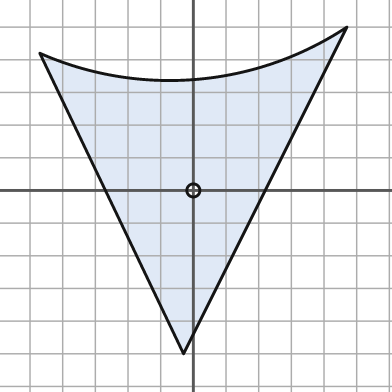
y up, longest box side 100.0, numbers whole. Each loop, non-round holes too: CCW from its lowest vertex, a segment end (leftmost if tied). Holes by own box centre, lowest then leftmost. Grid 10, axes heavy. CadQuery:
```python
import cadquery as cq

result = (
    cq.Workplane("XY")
    .moveTo(-3.0, -50.0)
    .lineTo(47.0, 50.0)
    .threePointArc((1.0, 34.0), (-47.0, 42.0))
    .close()
    .moveTo(0.0, 0.0)
    .circle(2.0)
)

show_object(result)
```